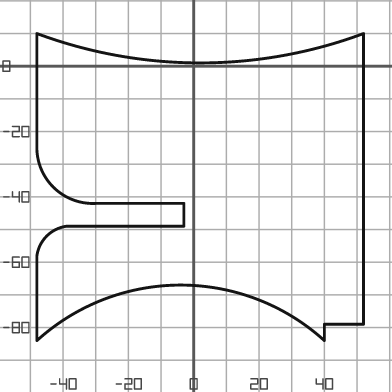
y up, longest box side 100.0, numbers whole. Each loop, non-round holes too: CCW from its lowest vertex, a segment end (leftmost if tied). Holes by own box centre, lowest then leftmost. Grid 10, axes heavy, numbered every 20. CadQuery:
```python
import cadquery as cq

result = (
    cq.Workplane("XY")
    .moveTo(-48.0, -84.0)
    .threePointArc((-4.0, -67.0), (40.0, -84.0))
    .lineTo(40.0, -79.0)
    .lineTo(52.0, -79.0)
    .lineTo(52.0, 10.0)
    .threePointArc((2.0, 1.0), (-48.0, 10.0))
    .lineTo(-48.0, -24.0)
    .threePointArc((-43.0, -37.0), (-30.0, -42.0))
    .lineTo(-3.0, -42.0)
    .lineTo(-3.0, -49.0)
    .lineTo(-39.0, -49.0)
    .threePointArc((-45.0, -52.0), (-48.0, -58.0))
    .close()
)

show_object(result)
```